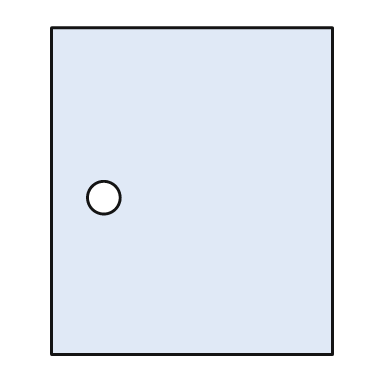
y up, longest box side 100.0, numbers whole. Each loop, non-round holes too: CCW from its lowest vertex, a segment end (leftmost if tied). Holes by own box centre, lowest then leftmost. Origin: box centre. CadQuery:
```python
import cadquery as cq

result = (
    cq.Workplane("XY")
    .moveTo(-43.0, -50.0)
    .lineTo(43.0, -50.0)
    .lineTo(43.0, 50.0)
    .lineTo(-43.0, 50.0)
    .close()
    .moveTo(-27.0, -2.0)
    .circle(5.0)
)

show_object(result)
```